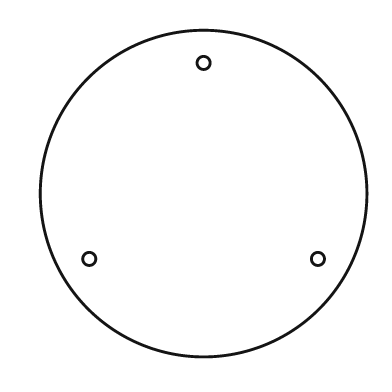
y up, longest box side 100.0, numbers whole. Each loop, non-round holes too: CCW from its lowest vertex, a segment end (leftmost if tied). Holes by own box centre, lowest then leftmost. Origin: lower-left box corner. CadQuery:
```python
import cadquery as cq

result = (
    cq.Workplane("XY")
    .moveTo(50.0, 50.0)
    .circle(50.0)
    .moveTo(15.0, 30.0)
    .circle(2.0)
    .moveTo(85.0, 30.0)
    .circle(2.0)
    .moveTo(50.0, 90.0)
    .circle(2.0)
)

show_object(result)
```